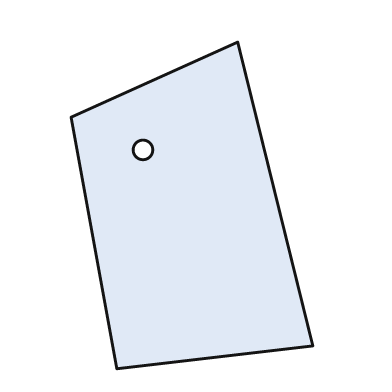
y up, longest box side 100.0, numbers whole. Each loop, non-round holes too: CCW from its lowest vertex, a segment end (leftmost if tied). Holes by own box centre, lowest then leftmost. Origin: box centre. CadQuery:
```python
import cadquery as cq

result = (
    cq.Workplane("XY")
    .moveTo(-23.0, -50.0)
    .lineTo(37.0, -43.0)
    .lineTo(14.0, 50.0)
    .lineTo(-37.0, 27.0)
    .close()
    .moveTo(-15.0, 17.0)
    .circle(3.0)
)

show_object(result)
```